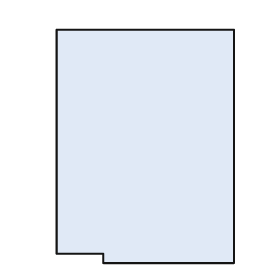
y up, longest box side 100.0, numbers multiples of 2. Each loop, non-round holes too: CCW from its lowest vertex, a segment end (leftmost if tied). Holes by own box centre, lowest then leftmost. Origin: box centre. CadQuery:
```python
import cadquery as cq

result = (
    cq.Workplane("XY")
    .moveTo(-18.0, -50.0)
    .lineTo(38.0, -50.0)
    .lineTo(38.0, 50.0)
    .lineTo(-38.0, 50.0)
    .lineTo(-38.0, -46.0)
    .lineTo(-18.0, -46.0)
    .close()
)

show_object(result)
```